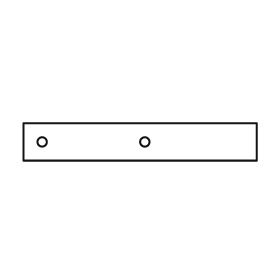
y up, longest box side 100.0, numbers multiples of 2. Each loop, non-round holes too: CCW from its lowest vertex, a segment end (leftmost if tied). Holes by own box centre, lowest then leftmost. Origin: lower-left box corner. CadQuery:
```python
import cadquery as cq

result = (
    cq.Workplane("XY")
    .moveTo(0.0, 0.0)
    .lineTo(100.0, 0.0)
    .lineTo(100.0, 16.0)
    .lineTo(0.0, 16.0)
    .close()
    .moveTo(8.0, 8.0)
    .circle(2.0)
    .moveTo(52.0, 8.0)
    .circle(2.0)
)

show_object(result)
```